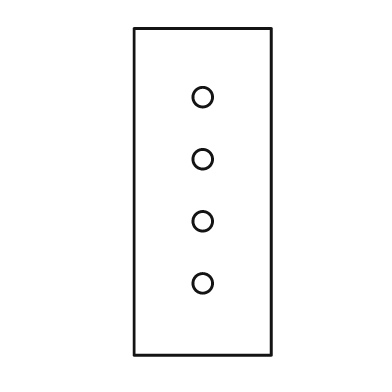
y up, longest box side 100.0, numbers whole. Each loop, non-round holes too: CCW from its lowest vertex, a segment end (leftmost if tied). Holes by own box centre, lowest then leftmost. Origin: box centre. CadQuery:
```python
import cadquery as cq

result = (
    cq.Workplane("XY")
    .moveTo(-21.0, -50.0)
    .lineTo(21.0, -50.0)
    .lineTo(21.0, 50.0)
    .lineTo(-21.0, 50.0)
    .close()
    .moveTo(0.0, -28.0)
    .circle(3.0)
    .moveTo(0.0, -9.0)
    .circle(3.0)
    .moveTo(0.0, 10.0)
    .circle(3.0)
    .moveTo(0.0, 29.0)
    .circle(3.0)
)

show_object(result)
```